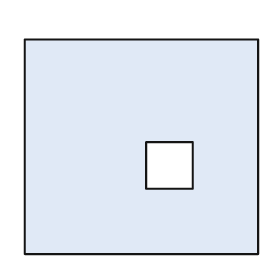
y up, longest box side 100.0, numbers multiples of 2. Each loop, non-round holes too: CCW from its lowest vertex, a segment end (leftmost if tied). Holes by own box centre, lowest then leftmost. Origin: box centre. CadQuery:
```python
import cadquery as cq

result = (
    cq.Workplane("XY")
    .moveTo(-50.0, -46.0)
    .lineTo(50.0, -46.0)
    .lineTo(50.0, 46.0)
    .lineTo(-50.0, 46.0)
    .close()
    .moveTo(2.0, -18.0)
    .lineTo(22.0, -18.0)
    .lineTo(22.0, 2.0)
    .lineTo(2.0, 2.0)
    .close()
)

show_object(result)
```